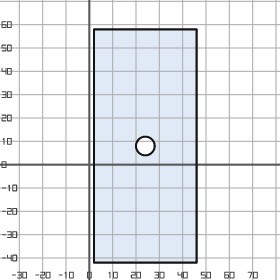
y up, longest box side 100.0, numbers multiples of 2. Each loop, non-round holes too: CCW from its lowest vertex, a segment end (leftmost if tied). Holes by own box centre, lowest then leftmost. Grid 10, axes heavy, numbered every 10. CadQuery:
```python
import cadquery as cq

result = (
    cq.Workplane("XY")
    .moveTo(2.0, -42.0)
    .lineTo(46.0, -42.0)
    .lineTo(46.0, 58.0)
    .lineTo(2.0, 58.0)
    .close()
    .moveTo(24.0, 8.0)
    .circle(4.0)
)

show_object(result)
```